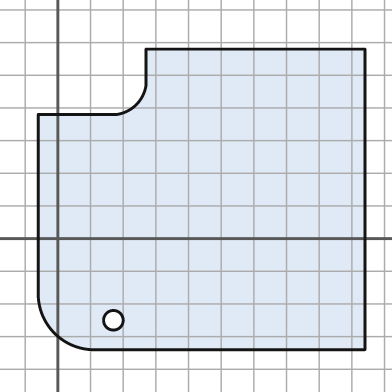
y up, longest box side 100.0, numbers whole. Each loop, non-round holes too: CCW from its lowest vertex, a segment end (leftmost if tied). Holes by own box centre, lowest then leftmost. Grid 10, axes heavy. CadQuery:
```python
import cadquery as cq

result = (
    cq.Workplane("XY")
    .moveTo(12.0, -34.0)
    .lineTo(94.0, -34.0)
    .lineTo(94.0, 58.0)
    .lineTo(27.0, 58.0)
    .lineTo(27.0, 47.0)
    .threePointArc((24.0, 41.0), (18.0, 38.0))
    .lineTo(-6.0, 38.0)
    .lineTo(-6.0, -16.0)
    .threePointArc((-1.0, -29.0), (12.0, -34.0))
    .close()
    .moveTo(17.0, -25.0)
    .circle(3.0)
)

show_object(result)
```